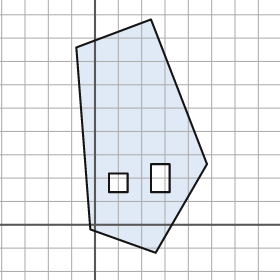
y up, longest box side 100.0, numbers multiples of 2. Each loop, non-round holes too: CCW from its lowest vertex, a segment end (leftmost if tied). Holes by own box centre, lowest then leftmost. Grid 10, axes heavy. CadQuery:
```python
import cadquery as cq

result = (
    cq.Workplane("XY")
    .moveTo(26.0, -12.0)
    .lineTo(48.0, 26.0)
    .lineTo(24.0, 88.0)
    .lineTo(-8.0, 76.0)
    .lineTo(-2.0, -2.0)
    .close()
    .moveTo(6.0, 14.0)
    .lineTo(14.0, 14.0)
    .lineTo(14.0, 22.0)
    .lineTo(6.0, 22.0)
    .close()
    .moveTo(24.0, 14.0)
    .lineTo(32.0, 14.0)
    .lineTo(32.0, 26.0)
    .lineTo(24.0, 26.0)
    .close()
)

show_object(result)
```